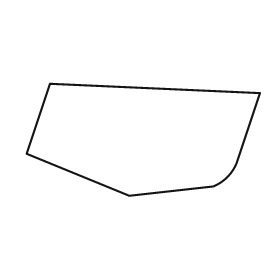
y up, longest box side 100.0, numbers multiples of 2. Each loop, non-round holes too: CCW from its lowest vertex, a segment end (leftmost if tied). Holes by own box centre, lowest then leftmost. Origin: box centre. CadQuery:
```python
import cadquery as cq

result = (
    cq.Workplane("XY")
    .moveTo(-6.0, -24.0)
    .lineTo(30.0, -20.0)
    .threePointArc((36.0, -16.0), (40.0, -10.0))
    .lineTo(50.0, 20.0)
    .lineTo(-40.0, 24.0)
    .lineTo(-50.0, -6.0)
    .close()
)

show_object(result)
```